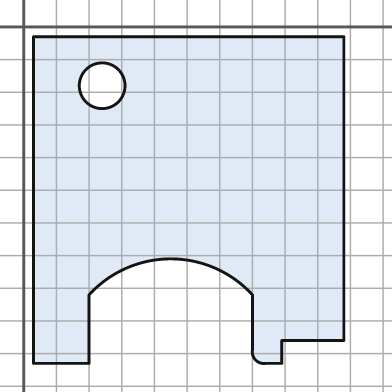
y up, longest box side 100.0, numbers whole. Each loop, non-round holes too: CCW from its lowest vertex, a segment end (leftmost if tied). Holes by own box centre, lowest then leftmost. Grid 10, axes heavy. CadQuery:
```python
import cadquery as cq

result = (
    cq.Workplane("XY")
    .moveTo(3.0, -103.0)
    .lineTo(20.0, -103.0)
    .lineTo(20.0, -82.0)
    .threePointArc((45.0, -71.0), (70.0, -82.0))
    .lineTo(70.0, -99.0)
    .threePointArc((71.0, -102.0), (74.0, -103.0))
    .lineTo(79.0, -103.0)
    .lineTo(79.0, -96.0)
    .lineTo(98.0, -96.0)
    .lineTo(98.0, -3.0)
    .lineTo(3.0, -3.0)
    .close()
    .moveTo(24.0, -18.0)
    .circle(7.0)
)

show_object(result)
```